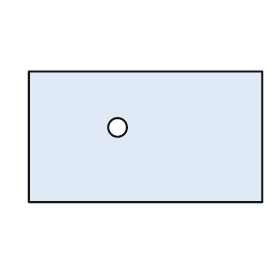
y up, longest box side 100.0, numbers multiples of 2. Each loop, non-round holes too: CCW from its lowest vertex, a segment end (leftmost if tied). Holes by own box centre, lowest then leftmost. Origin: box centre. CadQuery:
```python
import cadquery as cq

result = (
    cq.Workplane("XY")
    .moveTo(-50.0, -28.0)
    .lineTo(50.0, -28.0)
    .lineTo(50.0, 28.0)
    .lineTo(-50.0, 28.0)
    .close()
    .moveTo(-12.0, 4.0)
    .circle(4.0)
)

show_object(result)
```